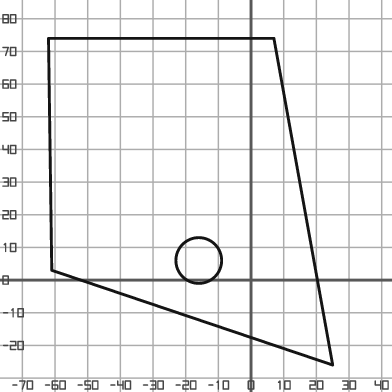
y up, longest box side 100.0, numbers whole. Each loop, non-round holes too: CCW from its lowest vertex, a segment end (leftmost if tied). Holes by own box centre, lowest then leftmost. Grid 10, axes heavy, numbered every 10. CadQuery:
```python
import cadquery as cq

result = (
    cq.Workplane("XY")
    .moveTo(25.0, -26.0)
    .lineTo(7.0, 74.0)
    .lineTo(-62.0, 74.0)
    .lineTo(-61.0, 3.0)
    .close()
    .moveTo(-16.0, 6.0)
    .circle(7.0)
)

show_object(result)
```